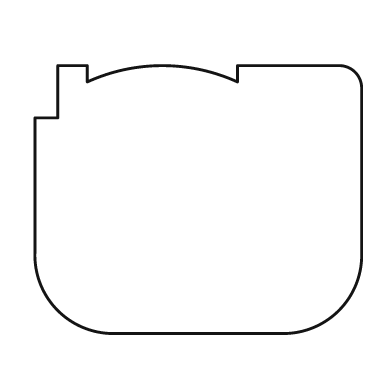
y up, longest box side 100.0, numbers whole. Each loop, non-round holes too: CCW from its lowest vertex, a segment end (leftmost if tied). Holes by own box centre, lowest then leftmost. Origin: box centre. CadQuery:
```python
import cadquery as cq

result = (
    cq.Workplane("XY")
    .moveTo(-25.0, -41.0)
    .lineTo(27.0, -41.0)
    .threePointArc((43.0, -34.0), (50.0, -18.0))
    .lineTo(50.0, 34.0)
    .threePointArc((48.0, 39.0), (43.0, 41.0))
    .lineTo(12.0, 41.0)
    .lineTo(12.0, 36.0)
    .threePointArc((-11.0, 41.0), (-34.0, 36.0))
    .lineTo(-34.0, 41.0)
    .lineTo(-43.0, 41.0)
    .lineTo(-43.0, 25.0)
    .lineTo(-50.0, 25.0)
    .lineTo(-50.0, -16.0)
    .threePointArc((-43.0, -34.0), (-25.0, -41.0))
    .close()
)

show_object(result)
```